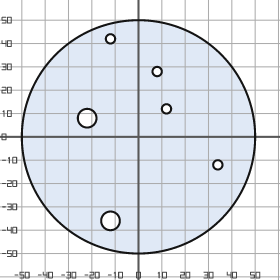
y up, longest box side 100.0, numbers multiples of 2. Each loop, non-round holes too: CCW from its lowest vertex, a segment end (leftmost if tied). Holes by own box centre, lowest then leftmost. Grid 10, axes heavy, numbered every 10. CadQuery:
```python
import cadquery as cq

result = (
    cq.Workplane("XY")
    .moveTo(0.0, 0.0)
    .circle(50.0)
    .moveTo(-12.0, -36.0)
    .circle(4.0)
    .moveTo(34.0, -12.0)
    .circle(2.0)
    .moveTo(-22.0, 8.0)
    .circle(4.0)
    .moveTo(12.0, 12.0)
    .circle(2.0)
    .moveTo(8.0, 28.0)
    .circle(2.0)
    .moveTo(-12.0, 42.0)
    .circle(2.0)
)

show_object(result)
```